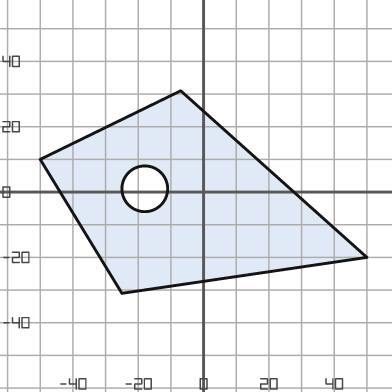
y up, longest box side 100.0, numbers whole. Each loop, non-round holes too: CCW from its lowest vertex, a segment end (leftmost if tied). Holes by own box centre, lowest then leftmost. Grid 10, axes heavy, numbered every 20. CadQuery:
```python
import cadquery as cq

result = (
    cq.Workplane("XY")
    .moveTo(-25.0, -31.0)
    .lineTo(50.0, -20.0)
    .lineTo(-7.0, 31.0)
    .lineTo(-50.0, 10.0)
    .close()
    .moveTo(-18.0, 1.0)
    .circle(7.0)
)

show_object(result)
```